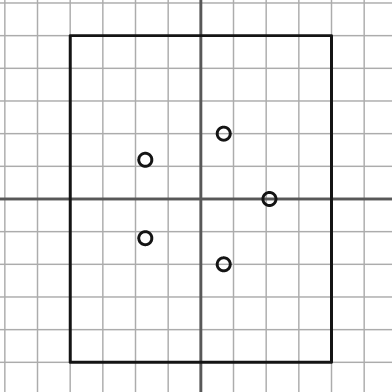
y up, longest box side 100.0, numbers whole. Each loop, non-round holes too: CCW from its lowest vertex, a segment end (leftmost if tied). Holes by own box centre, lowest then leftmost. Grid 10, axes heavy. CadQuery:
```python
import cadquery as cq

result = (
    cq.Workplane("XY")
    .moveTo(-40.0, -50.0)
    .lineTo(40.0, -50.0)
    .lineTo(40.0, 50.0)
    .lineTo(-40.0, 50.0)
    .close()
    .moveTo(7.0, -20.0)
    .circle(2.0)
    .moveTo(-17.0, -12.0)
    .circle(2.0)
    .moveTo(21.0, 0.0)
    .circle(2.0)
    .moveTo(-17.0, 12.0)
    .circle(2.0)
    .moveTo(7.0, 20.0)
    .circle(2.0)
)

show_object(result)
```